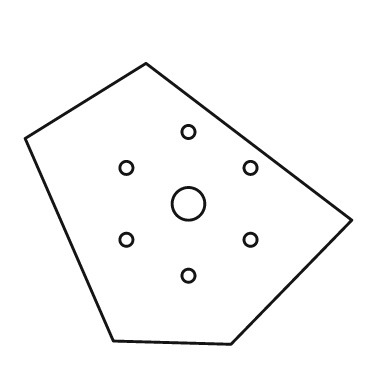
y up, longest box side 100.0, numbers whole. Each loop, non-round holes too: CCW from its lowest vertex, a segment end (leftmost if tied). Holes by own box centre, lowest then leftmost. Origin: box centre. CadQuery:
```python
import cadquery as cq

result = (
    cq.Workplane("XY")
    .moveTo(13.0, -43.0)
    .lineTo(50.0, -5.0)
    .lineTo(-13.0, 43.0)
    .lineTo(-50.0, 20.0)
    .lineTo(-23.0, -42.0)
    .close()
    .moveTo(0.0, -22.0)
    .circle(2.0)
    .moveTo(-19.0, -11.0)
    .circle(2.0)
    .moveTo(19.0, -11.0)
    .circle(2.0)
    .moveTo(0.0, 0.0)
    .circle(5.0)
    .moveTo(-19.0, 11.0)
    .circle(2.0)
    .moveTo(19.0, 11.0)
    .circle(2.0)
    .moveTo(0.0, 22.0)
    .circle(2.0)
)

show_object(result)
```